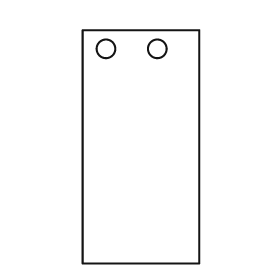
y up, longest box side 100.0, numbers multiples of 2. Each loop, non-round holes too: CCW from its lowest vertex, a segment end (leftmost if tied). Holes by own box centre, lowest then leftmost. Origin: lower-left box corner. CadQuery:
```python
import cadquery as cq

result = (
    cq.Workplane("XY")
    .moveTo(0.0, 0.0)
    .lineTo(50.0, 0.0)
    .lineTo(50.0, 100.0)
    .lineTo(0.0, 100.0)
    .close()
    .moveTo(10.0, 92.0)
    .circle(4.0)
    .moveTo(32.0, 92.0)
    .circle(4.0)
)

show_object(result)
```